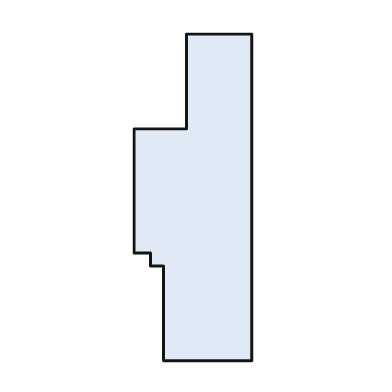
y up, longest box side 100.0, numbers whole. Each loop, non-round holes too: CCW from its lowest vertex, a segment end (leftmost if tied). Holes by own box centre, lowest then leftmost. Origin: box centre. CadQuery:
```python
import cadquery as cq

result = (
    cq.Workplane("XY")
    .moveTo(-9.0, -50.0)
    .lineTo(18.0, -50.0)
    .lineTo(18.0, 50.0)
    .lineTo(-2.0, 50.0)
    .lineTo(-2.0, 21.0)
    .lineTo(-18.0, 21.0)
    .lineTo(-18.0, -17.0)
    .lineTo(-13.0, -17.0)
    .lineTo(-13.0, -21.0)
    .lineTo(-9.0, -21.0)
    .close()
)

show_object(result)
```